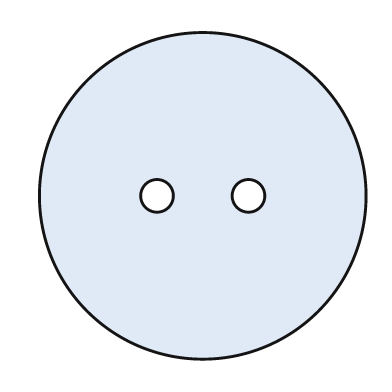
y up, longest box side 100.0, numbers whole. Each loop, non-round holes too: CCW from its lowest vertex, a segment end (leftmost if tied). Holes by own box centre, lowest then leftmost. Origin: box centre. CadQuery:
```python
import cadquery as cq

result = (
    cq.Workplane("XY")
    .moveTo(0.0, 0.0)
    .circle(50.0)
    .moveTo(-14.0, 0.0)
    .circle(5.0)
    .moveTo(14.0, 0.0)
    .circle(5.0)
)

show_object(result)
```